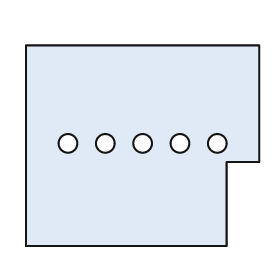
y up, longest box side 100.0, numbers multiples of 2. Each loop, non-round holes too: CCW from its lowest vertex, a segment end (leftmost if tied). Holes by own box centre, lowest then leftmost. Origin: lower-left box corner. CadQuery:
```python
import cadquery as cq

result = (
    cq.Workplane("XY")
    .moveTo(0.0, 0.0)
    .lineTo(86.0, 0.0)
    .lineTo(86.0, 36.0)
    .lineTo(100.0, 36.0)
    .lineTo(100.0, 86.0)
    .lineTo(0.0, 86.0)
    .close()
    .moveTo(18.0, 44.0)
    .circle(4.0)
    .moveTo(34.0, 44.0)
    .circle(4.0)
    .moveTo(50.0, 44.0)
    .circle(4.0)
    .moveTo(66.0, 44.0)
    .circle(4.0)
    .moveTo(82.0, 44.0)
    .circle(4.0)
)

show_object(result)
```